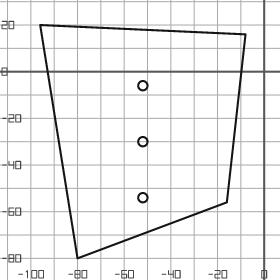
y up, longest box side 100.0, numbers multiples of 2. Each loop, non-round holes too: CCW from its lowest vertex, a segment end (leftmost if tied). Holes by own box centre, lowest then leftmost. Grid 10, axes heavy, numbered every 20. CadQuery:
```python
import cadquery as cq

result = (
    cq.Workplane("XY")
    .moveTo(-80.0, -80.0)
    .lineTo(-16.0, -56.0)
    .lineTo(-8.0, 16.0)
    .lineTo(-96.0, 20.0)
    .close()
    .moveTo(-52.0, -54.0)
    .circle(2.0)
    .moveTo(-52.0, -30.0)
    .circle(2.0)
    .moveTo(-52.0, -6.0)
    .circle(2.0)
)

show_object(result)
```